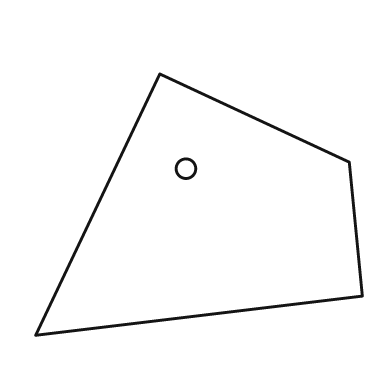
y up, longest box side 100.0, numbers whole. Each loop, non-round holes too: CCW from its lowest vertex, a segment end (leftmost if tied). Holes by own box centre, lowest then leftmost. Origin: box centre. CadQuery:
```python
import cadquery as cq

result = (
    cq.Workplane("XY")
    .moveTo(-50.0, -40.0)
    .lineTo(50.0, -28.0)
    .lineTo(46.0, 13.0)
    .lineTo(-12.0, 40.0)
    .close()
    .moveTo(-4.0, 11.0)
    .circle(3.0)
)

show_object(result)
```